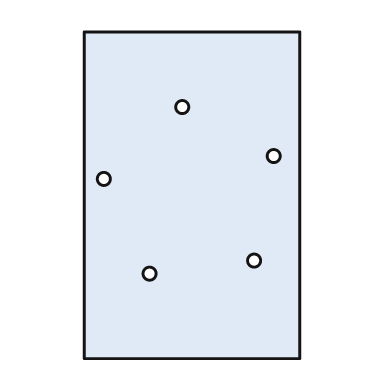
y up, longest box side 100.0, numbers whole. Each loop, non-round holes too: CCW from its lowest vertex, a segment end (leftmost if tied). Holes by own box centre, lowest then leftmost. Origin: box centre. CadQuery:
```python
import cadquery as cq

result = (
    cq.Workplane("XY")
    .moveTo(-33.0, -50.0)
    .lineTo(33.0, -50.0)
    .lineTo(33.0, 50.0)
    .lineTo(-33.0, 50.0)
    .close()
    .moveTo(-13.0, -24.0)
    .circle(2.0)
    .moveTo(19.0, -20.0)
    .circle(2.0)
    .moveTo(-27.0, 5.0)
    .circle(2.0)
    .moveTo(25.0, 12.0)
    .circle(2.0)
    .moveTo(-3.0, 27.0)
    .circle(2.0)
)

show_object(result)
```